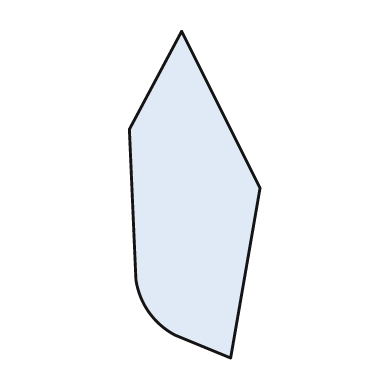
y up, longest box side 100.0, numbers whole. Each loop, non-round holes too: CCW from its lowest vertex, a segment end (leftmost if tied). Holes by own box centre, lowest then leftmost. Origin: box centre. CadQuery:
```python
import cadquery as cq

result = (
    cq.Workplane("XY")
    .moveTo(11.0, -50.0)
    .lineTo(20.0, 2.0)
    .lineTo(-4.0, 50.0)
    .lineTo(-20.0, 20.0)
    .lineTo(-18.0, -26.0)
    .threePointArc((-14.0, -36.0), (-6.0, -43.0))
    .close()
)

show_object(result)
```